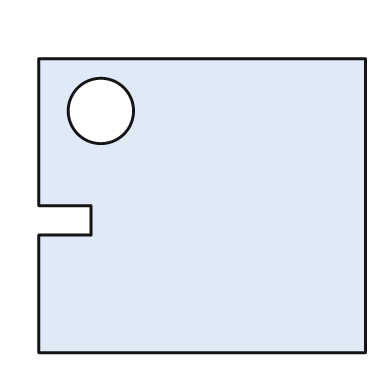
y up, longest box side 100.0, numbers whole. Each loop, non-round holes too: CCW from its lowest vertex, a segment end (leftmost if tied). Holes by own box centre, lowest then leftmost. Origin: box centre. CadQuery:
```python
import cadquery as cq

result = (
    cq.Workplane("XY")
    .moveTo(-50.0, -45.0)
    .lineTo(50.0, -45.0)
    .lineTo(50.0, 45.0)
    .lineTo(-50.0, 45.0)
    .lineTo(-50.0, 0.0)
    .lineTo(-34.0, 0.0)
    .lineTo(-34.0, -9.0)
    .lineTo(-50.0, -9.0)
    .close()
    .moveTo(-31.0, 29.0)
    .circle(10.0)
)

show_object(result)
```